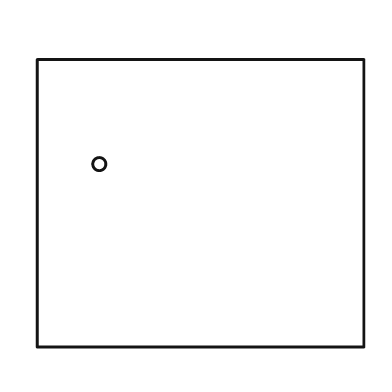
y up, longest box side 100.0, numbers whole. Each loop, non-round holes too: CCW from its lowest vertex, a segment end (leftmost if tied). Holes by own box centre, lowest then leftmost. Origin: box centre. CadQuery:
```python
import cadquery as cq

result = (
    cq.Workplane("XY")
    .moveTo(-50.0, -44.0)
    .lineTo(50.0, -44.0)
    .lineTo(50.0, 44.0)
    .lineTo(-50.0, 44.0)
    .close()
    .moveTo(-31.0, 12.0)
    .circle(2.0)
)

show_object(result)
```